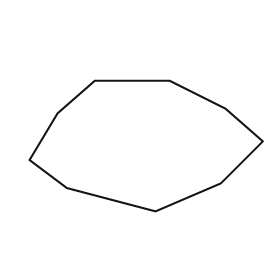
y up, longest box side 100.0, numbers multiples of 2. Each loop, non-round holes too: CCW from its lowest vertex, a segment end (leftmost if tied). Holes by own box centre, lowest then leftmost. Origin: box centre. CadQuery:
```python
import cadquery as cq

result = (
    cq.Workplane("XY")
    .moveTo(4.0, -28.0)
    .lineTo(32.0, -16.0)
    .lineTo(50.0, 2.0)
    .lineTo(34.0, 16.0)
    .lineTo(10.0, 28.0)
    .lineTo(-22.0, 28.0)
    .lineTo(-38.0, 14.0)
    .lineTo(-50.0, -6.0)
    .lineTo(-34.0, -18.0)
    .close()
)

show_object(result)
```